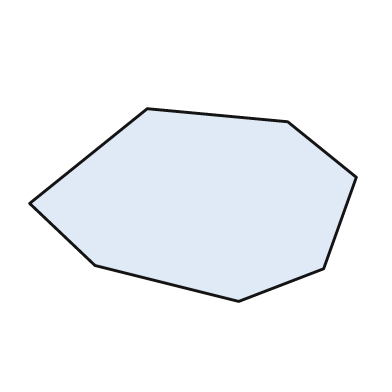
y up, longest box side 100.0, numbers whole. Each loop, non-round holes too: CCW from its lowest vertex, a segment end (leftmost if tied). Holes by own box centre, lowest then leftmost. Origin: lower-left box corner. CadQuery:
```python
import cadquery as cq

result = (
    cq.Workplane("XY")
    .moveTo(64.0, 0.0)
    .lineTo(90.0, 10.0)
    .lineTo(100.0, 38.0)
    .lineTo(79.0, 55.0)
    .lineTo(36.0, 59.0)
    .lineTo(0.0, 30.0)
    .lineTo(20.0, 11.0)
    .close()
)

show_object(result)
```